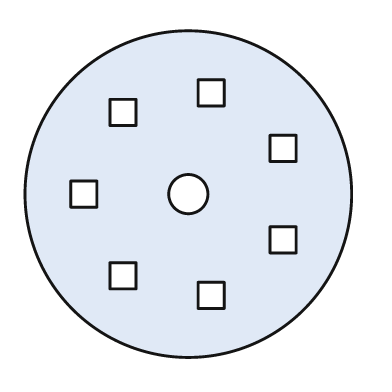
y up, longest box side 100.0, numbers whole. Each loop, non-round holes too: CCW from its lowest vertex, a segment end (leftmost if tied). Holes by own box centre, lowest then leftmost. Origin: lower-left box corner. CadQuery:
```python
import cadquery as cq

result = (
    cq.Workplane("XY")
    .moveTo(50.0, 50.0)
    .circle(50.0)
    .moveTo(53.0, 15.0)
    .lineTo(61.0, 15.0)
    .lineTo(61.0, 23.0)
    .lineTo(53.0, 23.0)
    .close()
    .moveTo(26.0, 21.0)
    .lineTo(34.0, 21.0)
    .lineTo(34.0, 29.0)
    .lineTo(26.0, 29.0)
    .close()
    .moveTo(75.0, 32.0)
    .lineTo(83.0, 32.0)
    .lineTo(83.0, 40.0)
    .lineTo(75.0, 40.0)
    .close()
    .moveTo(14.0, 46.0)
    .lineTo(22.0, 46.0)
    .lineTo(22.0, 54.0)
    .lineTo(14.0, 54.0)
    .close()
    .moveTo(50.0, 50.0)
    .circle(6.0)
    .moveTo(75.0, 60.0)
    .lineTo(83.0, 60.0)
    .lineTo(83.0, 68.0)
    .lineTo(75.0, 68.0)
    .close()
    .moveTo(26.0, 71.0)
    .lineTo(34.0, 71.0)
    .lineTo(34.0, 79.0)
    .lineTo(26.0, 79.0)
    .close()
    .moveTo(53.0, 77.0)
    .lineTo(61.0, 77.0)
    .lineTo(61.0, 85.0)
    .lineTo(53.0, 85.0)
    .close()
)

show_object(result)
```